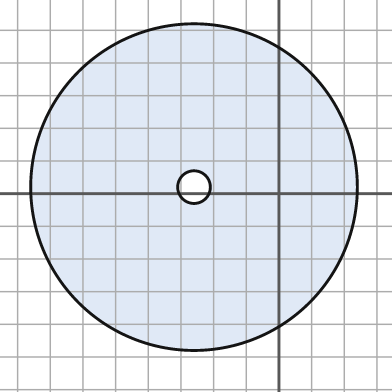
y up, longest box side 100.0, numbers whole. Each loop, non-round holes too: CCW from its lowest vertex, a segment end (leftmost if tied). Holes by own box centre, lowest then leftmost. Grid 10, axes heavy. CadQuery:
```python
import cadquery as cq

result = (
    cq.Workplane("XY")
    .moveTo(-26.0, 2.0)
    .circle(50.0)
    .moveTo(-26.0, 2.0)
    .circle(5.0)
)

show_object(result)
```